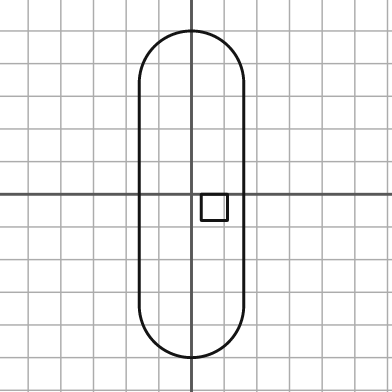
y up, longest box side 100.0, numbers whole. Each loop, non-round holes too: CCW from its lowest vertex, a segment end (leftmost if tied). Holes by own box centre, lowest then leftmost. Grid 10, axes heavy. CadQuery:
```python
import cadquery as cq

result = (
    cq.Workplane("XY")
    .moveTo(-16.0, -34.0)
    .threePointArc((0.0, -50.0), (16.0, -34.0))
    .lineTo(16.0, 34.0)
    .threePointArc((0.0, 50.0), (-16.0, 34.0))
    .close()
    .moveTo(3.0, -8.0)
    .lineTo(11.0, -8.0)
    .lineTo(11.0, 0.0)
    .lineTo(3.0, 0.0)
    .close()
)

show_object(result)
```